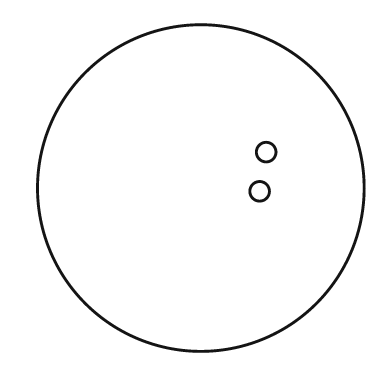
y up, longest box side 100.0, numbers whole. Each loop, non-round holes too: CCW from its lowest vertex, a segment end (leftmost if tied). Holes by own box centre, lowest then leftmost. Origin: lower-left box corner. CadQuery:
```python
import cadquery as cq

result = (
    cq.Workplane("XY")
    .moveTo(50.0, 50.0)
    .circle(50.0)
    .moveTo(68.0, 49.0)
    .circle(3.0)
    .moveTo(70.0, 61.0)
    .circle(3.0)
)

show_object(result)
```